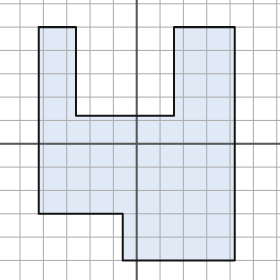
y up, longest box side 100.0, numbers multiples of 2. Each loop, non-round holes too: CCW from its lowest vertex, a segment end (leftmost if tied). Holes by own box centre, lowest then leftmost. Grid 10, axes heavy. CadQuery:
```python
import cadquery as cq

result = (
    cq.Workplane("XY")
    .moveTo(-6.0, -50.0)
    .lineTo(42.0, -50.0)
    .lineTo(42.0, 50.0)
    .lineTo(16.0, 50.0)
    .lineTo(16.0, 12.0)
    .lineTo(-26.0, 12.0)
    .lineTo(-26.0, 50.0)
    .lineTo(-42.0, 50.0)
    .lineTo(-42.0, -30.0)
    .lineTo(-6.0, -30.0)
    .close()
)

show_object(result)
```